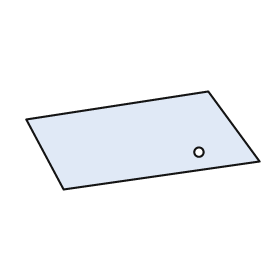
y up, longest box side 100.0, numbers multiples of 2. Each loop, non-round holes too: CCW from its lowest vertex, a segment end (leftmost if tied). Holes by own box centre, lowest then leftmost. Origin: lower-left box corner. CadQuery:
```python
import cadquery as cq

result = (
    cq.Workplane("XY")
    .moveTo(16.0, 0.0)
    .lineTo(100.0, 12.0)
    .lineTo(78.0, 42.0)
    .lineTo(0.0, 30.0)
    .close()
    .moveTo(74.0, 16.0)
    .circle(2.0)
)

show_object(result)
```